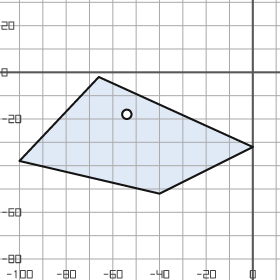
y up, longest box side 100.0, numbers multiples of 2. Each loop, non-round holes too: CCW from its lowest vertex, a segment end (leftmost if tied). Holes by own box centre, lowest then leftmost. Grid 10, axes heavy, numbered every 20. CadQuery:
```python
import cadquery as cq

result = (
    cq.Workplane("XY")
    .moveTo(-40.0, -52.0)
    .lineTo(0.0, -32.0)
    .lineTo(-66.0, -2.0)
    .lineTo(-100.0, -38.0)
    .close()
    .moveTo(-54.0, -18.0)
    .circle(2.0)
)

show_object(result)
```